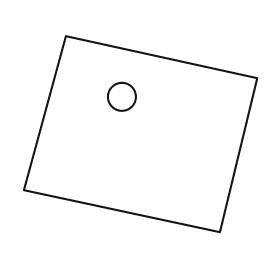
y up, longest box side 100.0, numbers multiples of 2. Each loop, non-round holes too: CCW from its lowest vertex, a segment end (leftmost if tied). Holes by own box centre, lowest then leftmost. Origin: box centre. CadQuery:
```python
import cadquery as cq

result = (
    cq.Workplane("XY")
    .moveTo(34.0, -42.0)
    .lineTo(50.0, 24.0)
    .lineTo(-32.0, 42.0)
    .lineTo(-50.0, -24.0)
    .close()
    .moveTo(-8.0, 16.0)
    .circle(6.0)
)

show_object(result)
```